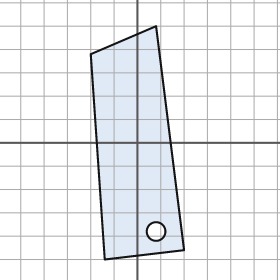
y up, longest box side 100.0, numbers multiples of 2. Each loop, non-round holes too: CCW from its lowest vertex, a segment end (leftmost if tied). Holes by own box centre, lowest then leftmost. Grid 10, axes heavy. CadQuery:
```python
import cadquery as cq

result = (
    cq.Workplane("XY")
    .moveTo(-14.0, -50.0)
    .lineTo(20.0, -46.0)
    .lineTo(8.0, 50.0)
    .lineTo(-20.0, 38.0)
    .close()
    .moveTo(8.0, -38.0)
    .circle(4.0)
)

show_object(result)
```